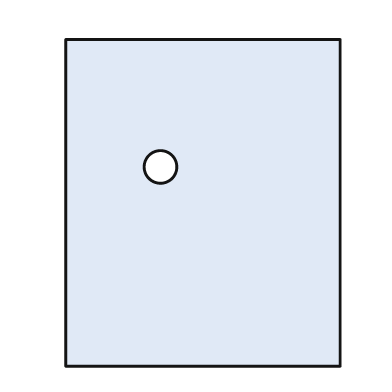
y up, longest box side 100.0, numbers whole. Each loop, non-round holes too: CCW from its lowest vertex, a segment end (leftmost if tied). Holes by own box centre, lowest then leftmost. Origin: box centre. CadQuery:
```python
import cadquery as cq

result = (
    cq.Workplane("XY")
    .moveTo(-42.0, -50.0)
    .lineTo(42.0, -50.0)
    .lineTo(42.0, 50.0)
    .lineTo(-42.0, 50.0)
    .close()
    .moveTo(-13.0, 11.0)
    .circle(5.0)
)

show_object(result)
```